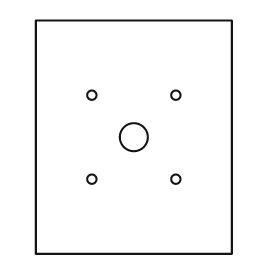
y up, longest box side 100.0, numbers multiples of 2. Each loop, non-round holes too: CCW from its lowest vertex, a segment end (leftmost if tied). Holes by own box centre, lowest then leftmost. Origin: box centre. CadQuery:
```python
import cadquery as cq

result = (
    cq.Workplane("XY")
    .moveTo(-42.0, -50.0)
    .lineTo(42.0, -50.0)
    .lineTo(42.0, 50.0)
    .lineTo(-42.0, 50.0)
    .close()
    .moveTo(-18.0, -18.0)
    .circle(2.0)
    .moveTo(18.0, -18.0)
    .circle(2.0)
    .moveTo(0.0, 0.0)
    .circle(6.0)
    .moveTo(-18.0, 18.0)
    .circle(2.0)
    .moveTo(18.0, 18.0)
    .circle(2.0)
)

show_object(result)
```